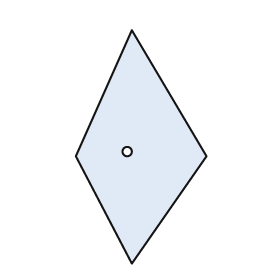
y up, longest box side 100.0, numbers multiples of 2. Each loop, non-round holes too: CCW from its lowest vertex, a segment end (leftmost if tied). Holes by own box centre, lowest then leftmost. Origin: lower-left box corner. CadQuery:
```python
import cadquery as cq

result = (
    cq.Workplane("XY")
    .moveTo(24.0, 0.0)
    .lineTo(56.0, 46.0)
    .lineTo(24.0, 100.0)
    .lineTo(0.0, 46.0)
    .close()
    .moveTo(22.0, 48.0)
    .circle(2.0)
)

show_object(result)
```